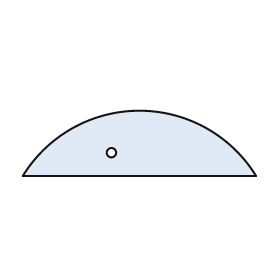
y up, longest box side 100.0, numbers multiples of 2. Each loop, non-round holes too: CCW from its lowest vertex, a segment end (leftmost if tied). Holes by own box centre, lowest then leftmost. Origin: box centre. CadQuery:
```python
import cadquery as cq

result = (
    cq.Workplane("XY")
    .moveTo(-50.0, -14.0)
    .lineTo(50.0, -14.0)
    .threePointArc((0.0, 14.0), (-50.0, -14.0))
    .close()
    .moveTo(-12.0, -4.0)
    .circle(2.0)
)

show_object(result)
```